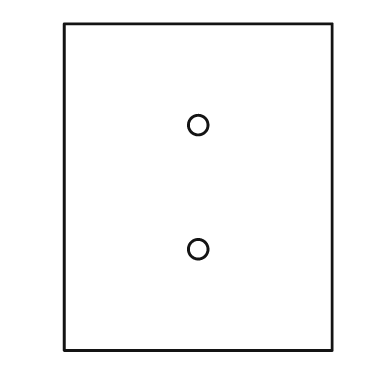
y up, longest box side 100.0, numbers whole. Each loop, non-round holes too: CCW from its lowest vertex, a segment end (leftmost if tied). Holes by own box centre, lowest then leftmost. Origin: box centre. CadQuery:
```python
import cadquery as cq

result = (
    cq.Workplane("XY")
    .moveTo(-41.0, -50.0)
    .lineTo(41.0, -50.0)
    .lineTo(41.0, 50.0)
    .lineTo(-41.0, 50.0)
    .close()
    .moveTo(0.0, -19.0)
    .circle(3.0)
    .moveTo(0.0, 19.0)
    .circle(3.0)
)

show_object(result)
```